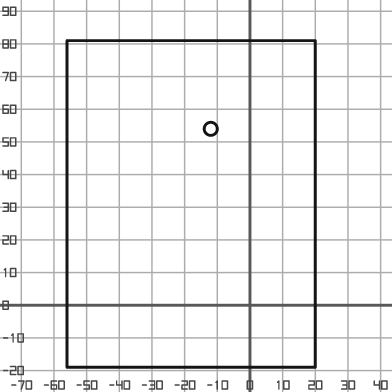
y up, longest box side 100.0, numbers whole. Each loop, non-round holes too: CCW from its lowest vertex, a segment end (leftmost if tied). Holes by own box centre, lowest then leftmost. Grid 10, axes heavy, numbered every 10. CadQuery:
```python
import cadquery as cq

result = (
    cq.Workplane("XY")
    .moveTo(-56.0, -19.0)
    .lineTo(20.0, -19.0)
    .lineTo(20.0, 81.0)
    .lineTo(-56.0, 81.0)
    .close()
    .moveTo(-12.0, 54.0)
    .circle(2.0)
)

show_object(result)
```